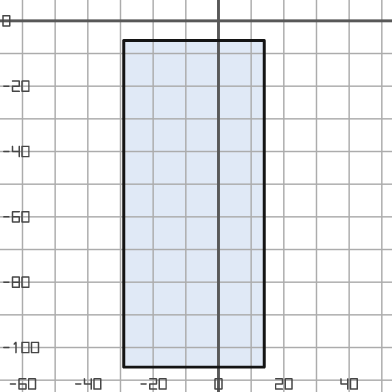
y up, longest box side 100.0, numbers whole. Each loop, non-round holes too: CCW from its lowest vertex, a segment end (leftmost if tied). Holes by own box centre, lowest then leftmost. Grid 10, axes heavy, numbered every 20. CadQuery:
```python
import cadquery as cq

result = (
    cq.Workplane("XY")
    .moveTo(-29.0, -106.0)
    .lineTo(14.0, -106.0)
    .lineTo(14.0, -6.0)
    .lineTo(-29.0, -6.0)
    .close()
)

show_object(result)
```